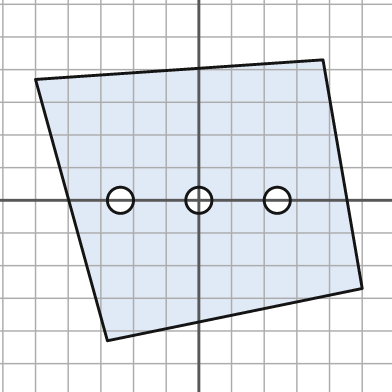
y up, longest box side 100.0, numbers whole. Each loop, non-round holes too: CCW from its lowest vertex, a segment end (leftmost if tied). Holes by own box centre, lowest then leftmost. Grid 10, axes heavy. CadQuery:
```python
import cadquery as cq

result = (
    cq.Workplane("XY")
    .moveTo(-28.0, -43.0)
    .lineTo(50.0, -27.0)
    .lineTo(38.0, 43.0)
    .lineTo(-50.0, 37.0)
    .close()
    .moveTo(-24.0, 0.0)
    .circle(4.0)
    .moveTo(0.0, 0.0)
    .circle(4.0)
    .moveTo(24.0, 0.0)
    .circle(4.0)
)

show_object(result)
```